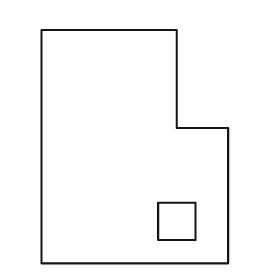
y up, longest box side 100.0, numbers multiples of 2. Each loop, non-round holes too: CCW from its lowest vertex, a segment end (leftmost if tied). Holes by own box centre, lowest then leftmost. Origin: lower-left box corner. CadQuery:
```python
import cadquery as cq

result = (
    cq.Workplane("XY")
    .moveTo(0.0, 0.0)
    .lineTo(80.0, 0.0)
    .lineTo(80.0, 58.0)
    .lineTo(58.0, 58.0)
    .lineTo(58.0, 100.0)
    .lineTo(0.0, 100.0)
    .close()
    .moveTo(50.0, 10.0)
    .lineTo(66.0, 10.0)
    .lineTo(66.0, 26.0)
    .lineTo(50.0, 26.0)
    .close()
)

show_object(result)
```